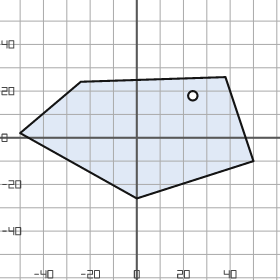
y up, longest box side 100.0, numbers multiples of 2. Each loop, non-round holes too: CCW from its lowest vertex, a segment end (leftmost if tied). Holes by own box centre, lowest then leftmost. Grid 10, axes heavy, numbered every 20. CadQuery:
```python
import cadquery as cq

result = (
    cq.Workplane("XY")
    .moveTo(0.0, -26.0)
    .lineTo(50.0, -10.0)
    .lineTo(38.0, 26.0)
    .lineTo(-24.0, 24.0)
    .lineTo(-50.0, 2.0)
    .close()
    .moveTo(24.0, 18.0)
    .circle(2.0)
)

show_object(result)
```